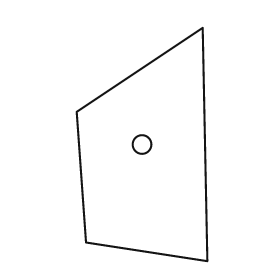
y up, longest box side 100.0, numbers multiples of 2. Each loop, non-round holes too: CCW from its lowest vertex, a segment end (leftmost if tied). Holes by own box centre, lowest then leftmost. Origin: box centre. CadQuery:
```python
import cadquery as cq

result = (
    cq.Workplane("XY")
    .moveTo(28.0, -50.0)
    .lineTo(26.0, 50.0)
    .lineTo(-28.0, 14.0)
    .lineTo(-24.0, -42.0)
    .close()
    .moveTo(0.0, 0.0)
    .circle(4.0)
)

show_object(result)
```